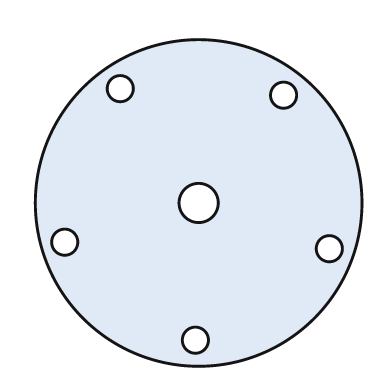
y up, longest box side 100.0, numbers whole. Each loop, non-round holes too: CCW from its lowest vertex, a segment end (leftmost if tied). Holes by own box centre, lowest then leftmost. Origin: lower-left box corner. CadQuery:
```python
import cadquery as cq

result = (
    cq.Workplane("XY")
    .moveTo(50.0, 50.0)
    .circle(50.0)
    .moveTo(49.0, 8.0)
    .circle(4.0)
    .moveTo(90.0, 36.0)
    .circle(4.0)
    .moveTo(9.0, 38.0)
    .circle(4.0)
    .moveTo(50.0, 50.0)
    .circle(6.0)
    .moveTo(76.0, 83.0)
    .circle(4.0)
    .moveTo(26.0, 85.0)
    .circle(4.0)
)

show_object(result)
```